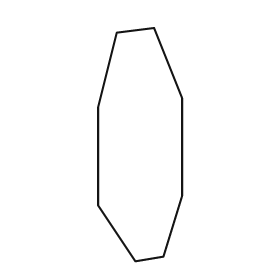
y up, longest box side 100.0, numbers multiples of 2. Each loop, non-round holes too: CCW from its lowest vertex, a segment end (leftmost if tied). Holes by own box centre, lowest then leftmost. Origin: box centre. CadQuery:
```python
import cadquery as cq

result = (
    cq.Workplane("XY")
    .moveTo(-2.0, -50.0)
    .lineTo(10.0, -48.0)
    .lineTo(18.0, -22.0)
    .lineTo(18.0, 20.0)
    .lineTo(6.0, 50.0)
    .lineTo(-10.0, 48.0)
    .lineTo(-18.0, 16.0)
    .lineTo(-18.0, -26.0)
    .close()
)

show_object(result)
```